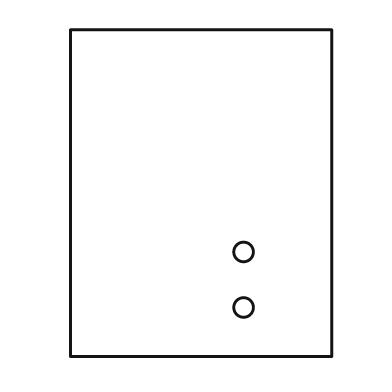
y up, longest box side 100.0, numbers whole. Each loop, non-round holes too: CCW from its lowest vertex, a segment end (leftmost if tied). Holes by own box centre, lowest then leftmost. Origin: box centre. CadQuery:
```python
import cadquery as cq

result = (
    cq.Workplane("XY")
    .moveTo(-40.0, -50.0)
    .lineTo(40.0, -50.0)
    .lineTo(40.0, 50.0)
    .lineTo(-40.0, 50.0)
    .close()
    .moveTo(13.0, -35.0)
    .circle(3.0)
    .moveTo(13.0, -18.0)
    .circle(3.0)
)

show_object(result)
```